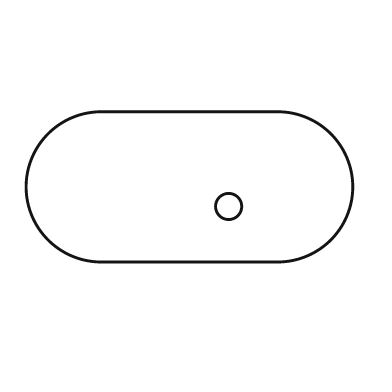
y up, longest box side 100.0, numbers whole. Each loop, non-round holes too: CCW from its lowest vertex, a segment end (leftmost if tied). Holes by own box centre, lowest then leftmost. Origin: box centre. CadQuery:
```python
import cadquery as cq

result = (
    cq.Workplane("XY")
    .moveTo(-27.0, -23.0)
    .lineTo(27.0, -23.0)
    .threePointArc((50.0, 0.0), (27.0, 23.0))
    .lineTo(-27.0, 23.0)
    .threePointArc((-50.0, 0.0), (-27.0, -23.0))
    .close()
    .moveTo(12.0, -6.0)
    .circle(4.0)
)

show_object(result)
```